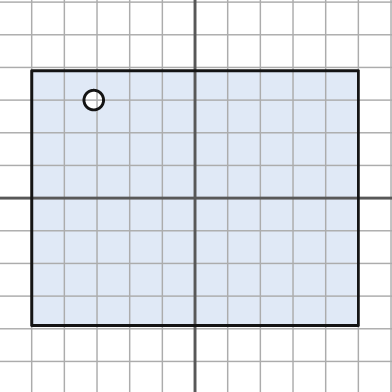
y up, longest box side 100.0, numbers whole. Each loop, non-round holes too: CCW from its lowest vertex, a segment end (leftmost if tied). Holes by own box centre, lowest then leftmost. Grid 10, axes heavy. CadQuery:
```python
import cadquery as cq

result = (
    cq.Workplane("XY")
    .moveTo(-50.0, -39.0)
    .lineTo(50.0, -39.0)
    .lineTo(50.0, 39.0)
    .lineTo(-50.0, 39.0)
    .close()
    .moveTo(-31.0, 30.0)
    .circle(3.0)
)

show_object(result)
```